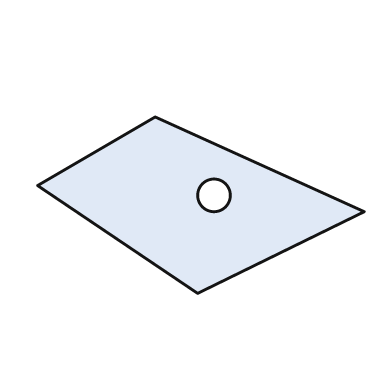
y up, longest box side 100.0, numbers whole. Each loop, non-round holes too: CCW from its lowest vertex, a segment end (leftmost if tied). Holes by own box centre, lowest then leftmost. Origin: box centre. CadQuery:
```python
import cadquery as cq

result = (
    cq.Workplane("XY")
    .moveTo(-1.0, -27.0)
    .lineTo(50.0, -2.0)
    .lineTo(-14.0, 27.0)
    .lineTo(-50.0, 6.0)
    .close()
    .moveTo(4.0, 3.0)
    .circle(5.0)
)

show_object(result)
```